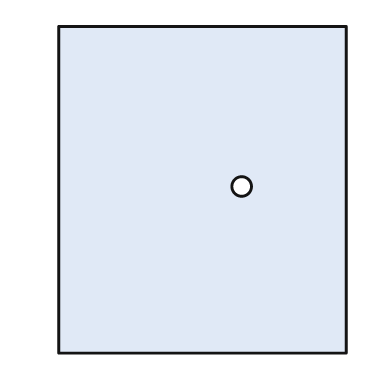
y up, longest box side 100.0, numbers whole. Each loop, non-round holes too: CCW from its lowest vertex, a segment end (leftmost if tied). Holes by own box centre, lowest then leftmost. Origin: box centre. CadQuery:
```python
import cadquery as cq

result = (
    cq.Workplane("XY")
    .moveTo(-44.0, -50.0)
    .lineTo(44.0, -50.0)
    .lineTo(44.0, 50.0)
    .lineTo(-44.0, 50.0)
    .close()
    .moveTo(12.0, 1.0)
    .circle(3.0)
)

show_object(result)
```